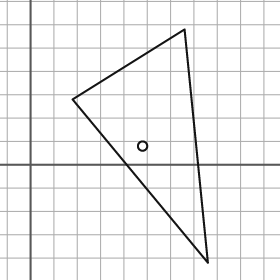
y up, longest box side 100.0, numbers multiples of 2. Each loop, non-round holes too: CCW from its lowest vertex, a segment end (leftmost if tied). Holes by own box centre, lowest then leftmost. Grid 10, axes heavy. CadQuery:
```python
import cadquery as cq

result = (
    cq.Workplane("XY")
    .moveTo(76.0, -42.0)
    .lineTo(66.0, 58.0)
    .lineTo(18.0, 28.0)
    .close()
    .moveTo(48.0, 8.0)
    .circle(2.0)
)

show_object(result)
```